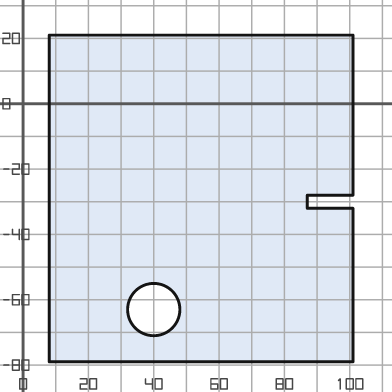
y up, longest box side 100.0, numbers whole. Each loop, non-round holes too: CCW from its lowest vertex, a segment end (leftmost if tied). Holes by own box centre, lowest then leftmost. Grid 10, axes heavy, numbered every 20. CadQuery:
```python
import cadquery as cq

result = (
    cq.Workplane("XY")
    .moveTo(8.0, -79.0)
    .lineTo(101.0, -79.0)
    .lineTo(101.0, -32.0)
    .lineTo(87.0, -32.0)
    .lineTo(87.0, -28.0)
    .lineTo(101.0, -28.0)
    .lineTo(101.0, 21.0)
    .lineTo(8.0, 21.0)
    .close()
    .moveTo(40.0, -63.0)
    .circle(8.0)
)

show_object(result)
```